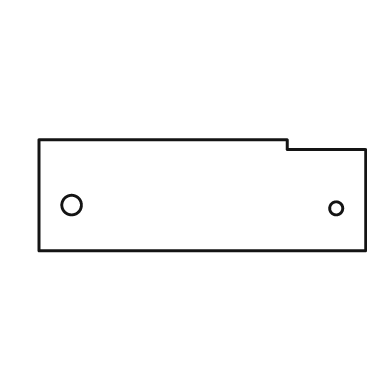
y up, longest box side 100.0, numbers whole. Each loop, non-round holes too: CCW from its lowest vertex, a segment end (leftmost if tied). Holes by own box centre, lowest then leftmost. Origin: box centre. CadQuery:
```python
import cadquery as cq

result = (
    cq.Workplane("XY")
    .moveTo(-50.0, -17.0)
    .lineTo(50.0, -17.0)
    .lineTo(50.0, 14.0)
    .lineTo(26.0, 14.0)
    .lineTo(26.0, 17.0)
    .lineTo(-50.0, 17.0)
    .close()
    .moveTo(41.0, -4.0)
    .circle(2.0)
    .moveTo(-40.0, -3.0)
    .circle(3.0)
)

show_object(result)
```